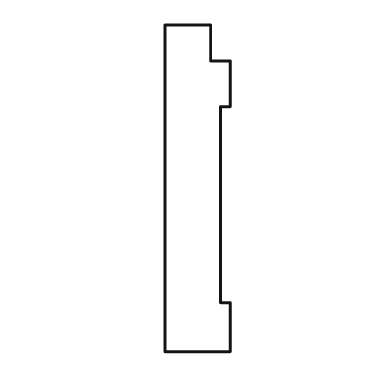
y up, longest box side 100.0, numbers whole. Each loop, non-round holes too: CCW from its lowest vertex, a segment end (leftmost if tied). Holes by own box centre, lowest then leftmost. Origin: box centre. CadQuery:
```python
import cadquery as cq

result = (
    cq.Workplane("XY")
    .moveTo(-10.0, -50.0)
    .lineTo(10.0, -50.0)
    .lineTo(10.0, -35.0)
    .lineTo(7.0, -35.0)
    .lineTo(7.0, 25.0)
    .lineTo(10.0, 25.0)
    .lineTo(10.0, 39.0)
    .lineTo(4.0, 39.0)
    .lineTo(4.0, 50.0)
    .lineTo(-10.0, 50.0)
    .close()
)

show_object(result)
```